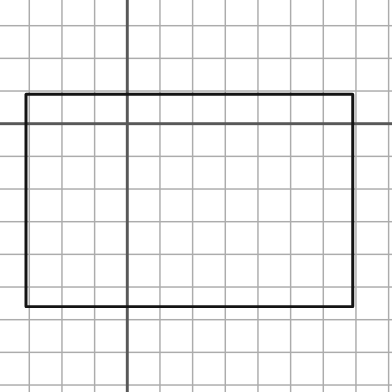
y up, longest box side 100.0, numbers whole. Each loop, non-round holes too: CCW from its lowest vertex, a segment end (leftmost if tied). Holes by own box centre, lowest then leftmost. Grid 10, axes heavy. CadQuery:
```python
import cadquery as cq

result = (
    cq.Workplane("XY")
    .moveTo(-31.0, -56.0)
    .lineTo(69.0, -56.0)
    .lineTo(69.0, 9.0)
    .lineTo(-31.0, 9.0)
    .close()
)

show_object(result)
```